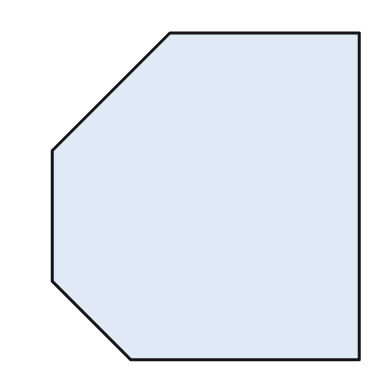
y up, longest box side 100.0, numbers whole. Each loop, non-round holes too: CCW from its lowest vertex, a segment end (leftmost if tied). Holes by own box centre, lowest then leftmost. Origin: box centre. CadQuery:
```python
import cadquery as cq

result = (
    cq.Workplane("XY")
    .moveTo(-23.0, -50.0)
    .lineTo(47.0, -50.0)
    .lineTo(47.0, 50.0)
    .lineTo(-11.0, 50.0)
    .lineTo(-47.0, 14.0)
    .lineTo(-47.0, -26.0)
    .close()
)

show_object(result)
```